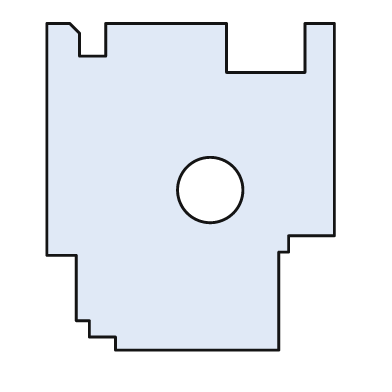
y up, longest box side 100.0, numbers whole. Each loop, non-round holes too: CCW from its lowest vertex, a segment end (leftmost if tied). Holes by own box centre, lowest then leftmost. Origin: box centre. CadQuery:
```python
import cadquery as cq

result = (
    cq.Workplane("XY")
    .moveTo(-23.0, -50.0)
    .lineTo(27.0, -50.0)
    .lineTo(27.0, -20.0)
    .lineTo(30.0, -20.0)
    .lineTo(30.0, -15.0)
    .lineTo(44.0, -15.0)
    .lineTo(44.0, 50.0)
    .lineTo(35.0, 50.0)
    .lineTo(35.0, 35.0)
    .lineTo(11.0, 35.0)
    .lineTo(11.0, 50.0)
    .lineTo(-26.0, 50.0)
    .lineTo(-26.0, 40.0)
    .lineTo(-34.0, 40.0)
    .lineTo(-34.0, 47.0)
    .lineTo(-37.0, 50.0)
    .lineTo(-44.0, 50.0)
    .lineTo(-44.0, -21.0)
    .lineTo(-35.0, -21.0)
    .lineTo(-35.0, -41.0)
    .lineTo(-31.0, -41.0)
    .lineTo(-31.0, -46.0)
    .lineTo(-23.0, -46.0)
    .close()
    .moveTo(6.0, -1.0)
    .circle(10.0)
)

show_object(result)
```